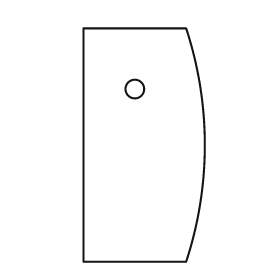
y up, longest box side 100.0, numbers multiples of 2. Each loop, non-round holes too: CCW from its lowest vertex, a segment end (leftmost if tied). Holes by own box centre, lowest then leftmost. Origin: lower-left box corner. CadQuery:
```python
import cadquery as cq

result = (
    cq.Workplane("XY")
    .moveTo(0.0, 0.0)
    .lineTo(44.0, 0.0)
    .threePointArc((52.0, 50.0), (44.0, 100.0))
    .lineTo(0.0, 100.0)
    .close()
    .moveTo(22.0, 74.0)
    .circle(4.0)
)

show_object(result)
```